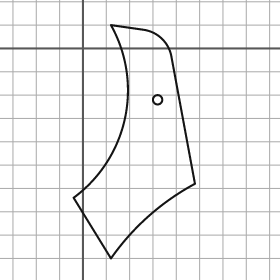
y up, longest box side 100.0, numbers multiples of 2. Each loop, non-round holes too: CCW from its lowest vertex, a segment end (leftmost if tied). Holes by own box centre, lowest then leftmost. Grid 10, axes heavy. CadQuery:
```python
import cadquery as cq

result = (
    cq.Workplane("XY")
    .moveTo(12.0, -90.0)
    .threePointArc((28.0, -72.0), (48.0, -58.0))
    .lineTo(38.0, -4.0)
    .threePointArc((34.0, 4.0), (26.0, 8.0))
    .lineTo(12.0, 10.0)
    .threePointArc((18.0, -30.0), (-4.0, -64.0))
    .close()
    .moveTo(32.0, -22.0)
    .circle(2.0)
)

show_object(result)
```